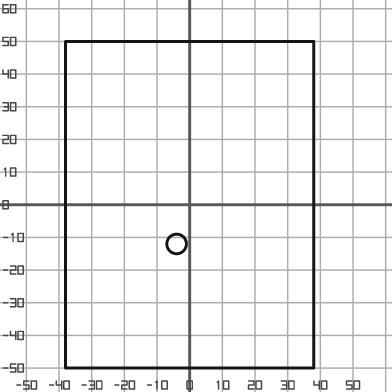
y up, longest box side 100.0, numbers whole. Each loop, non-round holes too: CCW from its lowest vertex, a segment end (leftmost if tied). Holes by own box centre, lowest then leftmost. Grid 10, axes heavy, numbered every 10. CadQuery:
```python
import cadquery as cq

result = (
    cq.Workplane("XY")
    .moveTo(-38.0, -50.0)
    .lineTo(38.0, -50.0)
    .lineTo(38.0, 50.0)
    .lineTo(-38.0, 50.0)
    .close()
    .moveTo(-4.0, -12.0)
    .circle(3.0)
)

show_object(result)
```